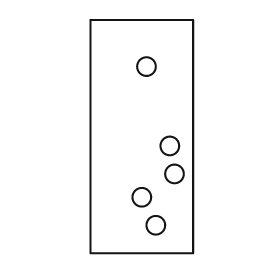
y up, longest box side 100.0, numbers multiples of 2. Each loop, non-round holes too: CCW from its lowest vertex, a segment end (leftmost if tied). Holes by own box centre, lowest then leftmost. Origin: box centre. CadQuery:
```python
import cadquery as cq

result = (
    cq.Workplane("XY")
    .moveTo(-22.0, -50.0)
    .lineTo(22.0, -50.0)
    .lineTo(22.0, 50.0)
    .lineTo(-22.0, 50.0)
    .close()
    .moveTo(6.0, -38.0)
    .circle(4.0)
    .moveTo(0.0, -26.0)
    .circle(4.0)
    .moveTo(14.0, -16.0)
    .circle(4.0)
    .moveTo(12.0, -4.0)
    .circle(4.0)
    .moveTo(2.0, 30.0)
    .circle(4.0)
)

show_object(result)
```